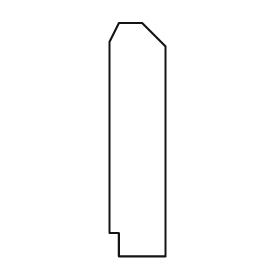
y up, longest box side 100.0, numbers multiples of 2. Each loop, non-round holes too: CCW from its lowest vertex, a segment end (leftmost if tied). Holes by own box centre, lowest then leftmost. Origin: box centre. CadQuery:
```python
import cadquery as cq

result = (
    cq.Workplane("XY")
    .moveTo(-8.0, -50.0)
    .lineTo(12.0, -50.0)
    .lineTo(12.0, 40.0)
    .lineTo(2.0, 50.0)
    .lineTo(-8.0, 50.0)
    .lineTo(-12.0, 42.0)
    .lineTo(-12.0, -40.0)
    .lineTo(-8.0, -40.0)
    .close()
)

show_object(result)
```